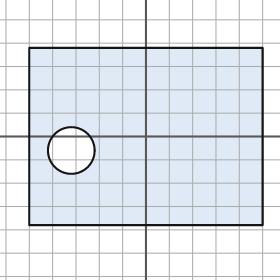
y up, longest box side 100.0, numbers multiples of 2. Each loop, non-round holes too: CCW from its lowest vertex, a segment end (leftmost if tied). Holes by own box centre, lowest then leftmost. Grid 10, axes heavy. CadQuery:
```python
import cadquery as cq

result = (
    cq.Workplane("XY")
    .moveTo(-50.0, -38.0)
    .lineTo(50.0, -38.0)
    .lineTo(50.0, 38.0)
    .lineTo(-50.0, 38.0)
    .close()
    .moveTo(-32.0, -6.0)
    .circle(10.0)
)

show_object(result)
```